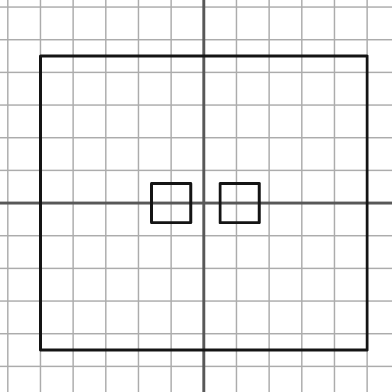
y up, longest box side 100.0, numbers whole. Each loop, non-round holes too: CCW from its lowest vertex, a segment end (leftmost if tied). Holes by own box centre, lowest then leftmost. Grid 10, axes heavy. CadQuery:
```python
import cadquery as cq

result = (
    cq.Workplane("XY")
    .moveTo(-50.0, -45.0)
    .lineTo(50.0, -45.0)
    .lineTo(50.0, 45.0)
    .lineTo(-50.0, 45.0)
    .close()
    .moveTo(-16.0, -6.0)
    .lineTo(-4.0, -6.0)
    .lineTo(-4.0, 6.0)
    .lineTo(-16.0, 6.0)
    .close()
    .moveTo(5.0, -6.0)
    .lineTo(17.0, -6.0)
    .lineTo(17.0, 6.0)
    .lineTo(5.0, 6.0)
    .close()
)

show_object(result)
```